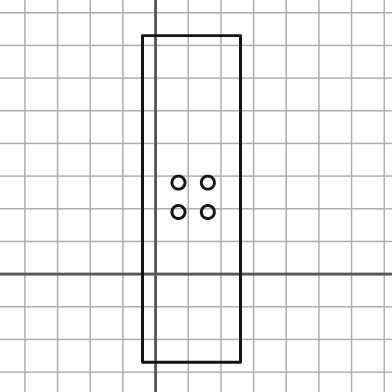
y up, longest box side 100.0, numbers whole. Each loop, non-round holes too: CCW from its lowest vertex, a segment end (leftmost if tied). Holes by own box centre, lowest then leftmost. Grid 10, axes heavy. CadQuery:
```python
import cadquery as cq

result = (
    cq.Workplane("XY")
    .moveTo(-4.0, -27.0)
    .lineTo(26.0, -27.0)
    .lineTo(26.0, 73.0)
    .lineTo(-4.0, 73.0)
    .close()
    .moveTo(7.0, 19.0)
    .circle(2.0)
    .moveTo(16.0, 19.0)
    .circle(2.0)
    .moveTo(7.0, 28.0)
    .circle(2.0)
    .moveTo(16.0, 28.0)
    .circle(2.0)
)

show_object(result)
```